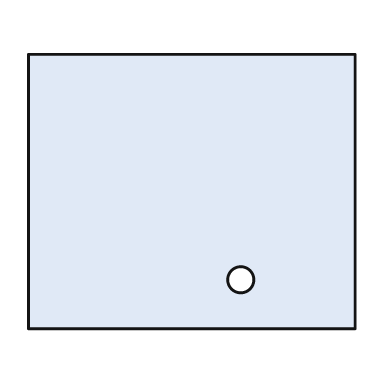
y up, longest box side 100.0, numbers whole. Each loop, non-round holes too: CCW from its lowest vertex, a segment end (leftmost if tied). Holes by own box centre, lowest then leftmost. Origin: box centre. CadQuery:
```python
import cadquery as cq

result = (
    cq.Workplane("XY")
    .moveTo(-50.0, -42.0)
    .lineTo(50.0, -42.0)
    .lineTo(50.0, 42.0)
    .lineTo(-50.0, 42.0)
    .close()
    .moveTo(15.0, -27.0)
    .circle(4.0)
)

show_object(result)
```